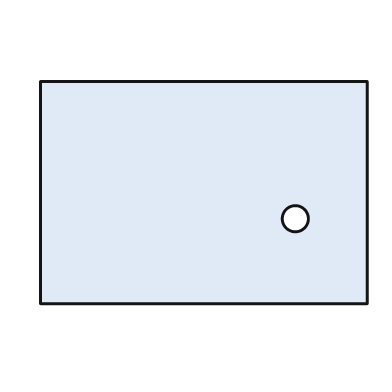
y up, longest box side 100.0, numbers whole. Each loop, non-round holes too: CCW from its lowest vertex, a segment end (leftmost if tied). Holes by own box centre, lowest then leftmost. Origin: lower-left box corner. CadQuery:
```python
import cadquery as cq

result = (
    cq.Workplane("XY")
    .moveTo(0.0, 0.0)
    .lineTo(100.0, 0.0)
    .lineTo(100.0, 68.0)
    .lineTo(0.0, 68.0)
    .close()
    .moveTo(78.0, 26.0)
    .circle(4.0)
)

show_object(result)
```